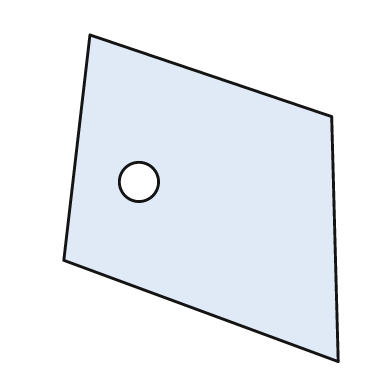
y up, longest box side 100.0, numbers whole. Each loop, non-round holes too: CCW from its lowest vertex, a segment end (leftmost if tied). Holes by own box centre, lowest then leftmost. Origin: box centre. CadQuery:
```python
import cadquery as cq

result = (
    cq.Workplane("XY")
    .moveTo(42.0, -50.0)
    .lineTo(40.0, 25.0)
    .lineTo(-34.0, 50.0)
    .lineTo(-42.0, -19.0)
    .close()
    .moveTo(-19.0, 5.0)
    .circle(6.0)
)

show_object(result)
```